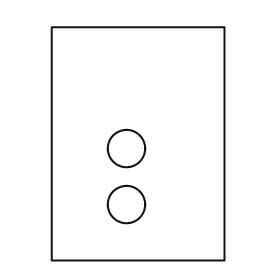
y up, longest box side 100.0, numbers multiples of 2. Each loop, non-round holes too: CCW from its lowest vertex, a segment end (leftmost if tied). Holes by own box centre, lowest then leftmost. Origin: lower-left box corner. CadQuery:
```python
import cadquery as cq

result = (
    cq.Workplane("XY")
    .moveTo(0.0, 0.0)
    .lineTo(74.0, 0.0)
    .lineTo(74.0, 100.0)
    .lineTo(0.0, 100.0)
    .close()
    .moveTo(32.0, 24.0)
    .circle(8.0)
    .moveTo(32.0, 48.0)
    .circle(8.0)
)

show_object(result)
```